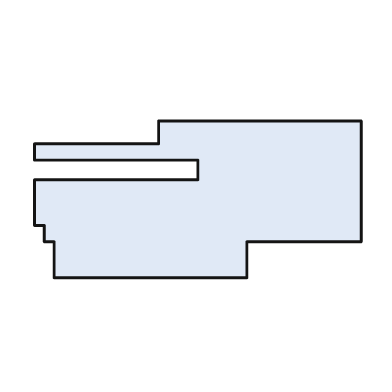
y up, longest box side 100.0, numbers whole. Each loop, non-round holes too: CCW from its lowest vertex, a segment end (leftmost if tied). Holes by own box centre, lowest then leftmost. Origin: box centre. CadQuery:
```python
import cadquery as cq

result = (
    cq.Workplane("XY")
    .moveTo(-44.0, -24.0)
    .lineTo(15.0, -24.0)
    .lineTo(15.0, -13.0)
    .lineTo(50.0, -13.0)
    .lineTo(50.0, 24.0)
    .lineTo(-12.0, 24.0)
    .lineTo(-12.0, 17.0)
    .lineTo(-50.0, 17.0)
    .lineTo(-50.0, 12.0)
    .lineTo(0.0, 12.0)
    .lineTo(0.0, 6.0)
    .lineTo(-50.0, 6.0)
    .lineTo(-50.0, -8.0)
    .lineTo(-47.0, -8.0)
    .lineTo(-47.0, -13.0)
    .lineTo(-44.0, -13.0)
    .close()
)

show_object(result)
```